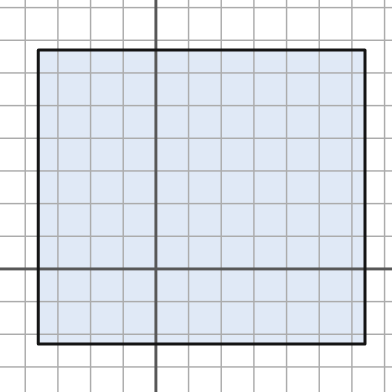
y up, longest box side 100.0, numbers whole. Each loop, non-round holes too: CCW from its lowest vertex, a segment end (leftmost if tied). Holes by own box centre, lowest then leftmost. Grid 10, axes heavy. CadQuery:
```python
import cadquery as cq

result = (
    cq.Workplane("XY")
    .moveTo(-36.0, -23.0)
    .lineTo(64.0, -23.0)
    .lineTo(64.0, 67.0)
    .lineTo(-36.0, 67.0)
    .close()
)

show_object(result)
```